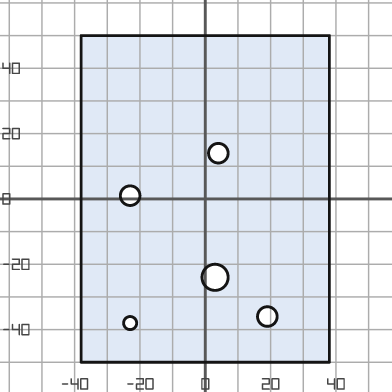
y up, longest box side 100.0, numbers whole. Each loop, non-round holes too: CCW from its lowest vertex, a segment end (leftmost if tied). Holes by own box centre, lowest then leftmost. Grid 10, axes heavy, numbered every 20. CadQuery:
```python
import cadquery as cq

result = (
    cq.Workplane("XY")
    .moveTo(-38.0, -50.0)
    .lineTo(38.0, -50.0)
    .lineTo(38.0, 50.0)
    .lineTo(-38.0, 50.0)
    .close()
    .moveTo(-23.0, -38.0)
    .circle(2.0)
    .moveTo(19.0, -36.0)
    .circle(3.0)
    .moveTo(3.0, -24.0)
    .circle(4.0)
    .moveTo(-23.0, 1.0)
    .circle(3.0)
    .moveTo(4.0, 14.0)
    .circle(3.0)
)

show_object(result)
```